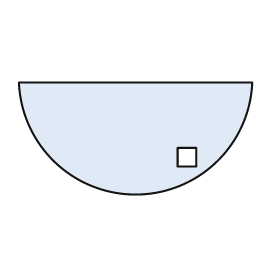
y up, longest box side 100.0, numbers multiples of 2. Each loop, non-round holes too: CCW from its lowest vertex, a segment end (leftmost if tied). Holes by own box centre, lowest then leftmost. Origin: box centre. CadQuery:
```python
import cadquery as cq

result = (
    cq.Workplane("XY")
    .moveTo(-50.0, 24.0)
    .threePointArc((0.0, -24.0), (50.0, 24.0))
    .close()
    .moveTo(18.0, -12.0)
    .lineTo(26.0, -12.0)
    .lineTo(26.0, -4.0)
    .lineTo(18.0, -4.0)
    .close()
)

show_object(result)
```